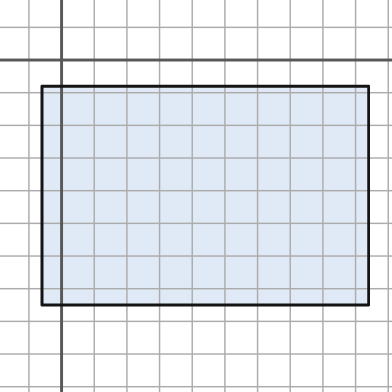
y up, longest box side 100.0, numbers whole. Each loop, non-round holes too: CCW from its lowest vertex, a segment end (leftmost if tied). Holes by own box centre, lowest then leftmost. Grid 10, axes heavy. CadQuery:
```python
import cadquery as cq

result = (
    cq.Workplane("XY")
    .moveTo(-6.0, -75.0)
    .lineTo(94.0, -75.0)
    .lineTo(94.0, -8.0)
    .lineTo(-6.0, -8.0)
    .close()
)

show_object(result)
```